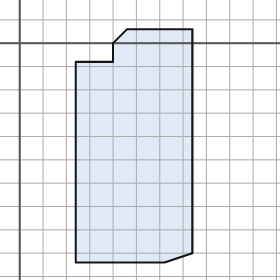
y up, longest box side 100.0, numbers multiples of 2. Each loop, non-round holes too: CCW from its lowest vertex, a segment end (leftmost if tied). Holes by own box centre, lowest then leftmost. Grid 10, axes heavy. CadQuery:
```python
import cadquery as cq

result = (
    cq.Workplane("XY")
    .moveTo(24.0, -94.0)
    .lineTo(62.0, -94.0)
    .lineTo(74.0, -90.0)
    .lineTo(74.0, 6.0)
    .lineTo(46.0, 6.0)
    .lineTo(40.0, 0.0)
    .lineTo(40.0, -8.0)
    .lineTo(24.0, -8.0)
    .close()
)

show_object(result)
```